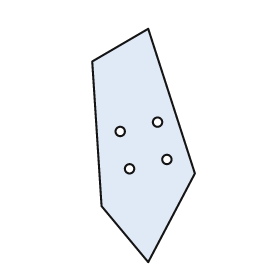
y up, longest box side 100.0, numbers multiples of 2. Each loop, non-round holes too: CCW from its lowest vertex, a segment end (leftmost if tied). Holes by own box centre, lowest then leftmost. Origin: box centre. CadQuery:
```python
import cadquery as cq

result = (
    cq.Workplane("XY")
    .moveTo(2.0, -50.0)
    .lineTo(22.0, -12.0)
    .lineTo(2.0, 50.0)
    .lineTo(-22.0, 36.0)
    .lineTo(-18.0, -26.0)
    .close()
    .moveTo(-6.0, -10.0)
    .circle(2.0)
    .moveTo(10.0, -6.0)
    .circle(2.0)
    .moveTo(-10.0, 6.0)
    .circle(2.0)
    .moveTo(6.0, 10.0)
    .circle(2.0)
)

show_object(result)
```